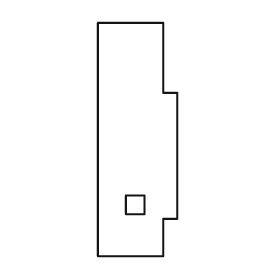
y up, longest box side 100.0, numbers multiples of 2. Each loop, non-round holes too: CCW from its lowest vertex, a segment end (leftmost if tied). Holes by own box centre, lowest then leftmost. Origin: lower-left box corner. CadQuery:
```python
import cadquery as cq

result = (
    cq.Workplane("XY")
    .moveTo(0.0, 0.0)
    .lineTo(28.0, 0.0)
    .lineTo(28.0, 16.0)
    .lineTo(34.0, 16.0)
    .lineTo(34.0, 70.0)
    .lineTo(28.0, 70.0)
    .lineTo(28.0, 100.0)
    .lineTo(0.0, 100.0)
    .close()
    .moveTo(12.0, 18.0)
    .lineTo(20.0, 18.0)
    .lineTo(20.0, 26.0)
    .lineTo(12.0, 26.0)
    .close()
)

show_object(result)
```